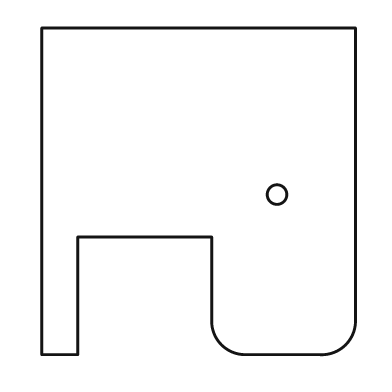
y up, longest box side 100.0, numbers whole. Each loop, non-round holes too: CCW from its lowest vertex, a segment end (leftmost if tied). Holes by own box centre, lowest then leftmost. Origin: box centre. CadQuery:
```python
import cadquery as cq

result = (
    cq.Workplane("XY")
    .moveTo(-48.0, -50.0)
    .lineTo(-37.0, -50.0)
    .lineTo(-37.0, -14.0)
    .lineTo(4.0, -14.0)
    .lineTo(4.0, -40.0)
    .threePointArc((7.0, -47.0), (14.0, -50.0))
    .lineTo(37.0, -50.0)
    .threePointArc((45.0, -47.0), (48.0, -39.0))
    .lineTo(48.0, 50.0)
    .lineTo(-48.0, 50.0)
    .close()
    .moveTo(24.0, -1.0)
    .circle(3.0)
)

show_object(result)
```